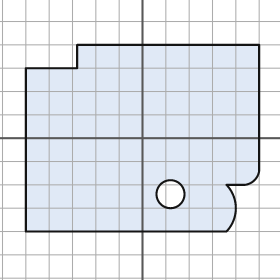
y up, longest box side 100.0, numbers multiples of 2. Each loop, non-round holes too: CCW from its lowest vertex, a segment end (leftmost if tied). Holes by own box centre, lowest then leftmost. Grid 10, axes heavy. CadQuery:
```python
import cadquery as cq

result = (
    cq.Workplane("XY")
    .moveTo(-50.0, -40.0)
    .lineTo(36.0, -40.0)
    .threePointArc((40.0, -30.0), (36.0, -20.0))
    .lineTo(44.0, -20.0)
    .threePointArc((48.0, -18.0), (50.0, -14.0))
    .lineTo(50.0, 40.0)
    .lineTo(-28.0, 40.0)
    .lineTo(-28.0, 30.0)
    .lineTo(-50.0, 30.0)
    .close()
    .moveTo(12.0, -24.0)
    .circle(6.0)
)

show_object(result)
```